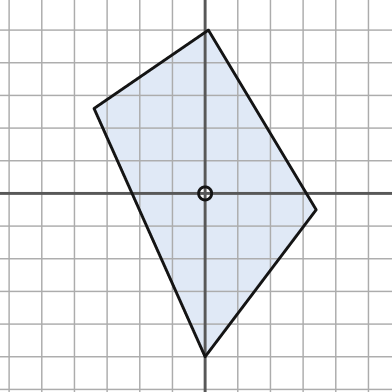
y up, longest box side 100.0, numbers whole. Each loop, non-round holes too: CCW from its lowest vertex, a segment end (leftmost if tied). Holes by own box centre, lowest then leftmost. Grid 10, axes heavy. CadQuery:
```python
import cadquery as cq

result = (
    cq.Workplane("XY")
    .moveTo(0.0, -50.0)
    .lineTo(34.0, -5.0)
    .lineTo(1.0, 50.0)
    .lineTo(-34.0, 26.0)
    .close()
    .moveTo(0.0, 0.0)
    .circle(2.0)
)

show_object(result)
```